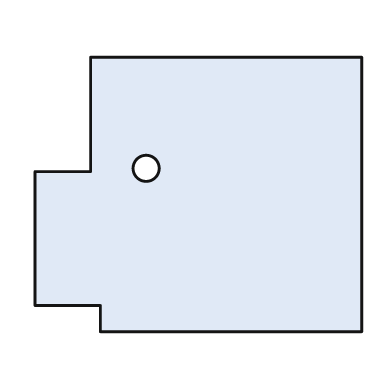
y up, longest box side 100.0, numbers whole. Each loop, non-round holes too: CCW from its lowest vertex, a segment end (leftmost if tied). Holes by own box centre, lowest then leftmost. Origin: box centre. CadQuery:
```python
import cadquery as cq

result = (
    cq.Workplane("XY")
    .moveTo(-30.0, -42.0)
    .lineTo(50.0, -42.0)
    .lineTo(50.0, 42.0)
    .lineTo(-33.0, 42.0)
    .lineTo(-33.0, 7.0)
    .lineTo(-50.0, 7.0)
    .lineTo(-50.0, -34.0)
    .lineTo(-30.0, -34.0)
    .close()
    .moveTo(-16.0, 8.0)
    .circle(4.0)
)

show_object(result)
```